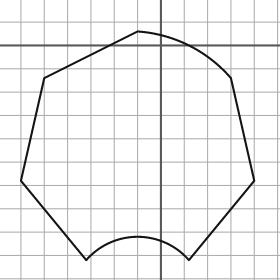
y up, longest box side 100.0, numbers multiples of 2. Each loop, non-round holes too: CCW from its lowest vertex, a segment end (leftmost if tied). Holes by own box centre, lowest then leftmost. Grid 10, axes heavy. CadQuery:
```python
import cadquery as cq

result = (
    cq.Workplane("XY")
    .moveTo(-32.0, -92.0)
    .threePointArc((-10.0, -82.0), (12.0, -92.0))
    .lineTo(40.0, -58.0)
    .lineTo(30.0, -14.0)
    .threePointArc((12.0, 0.0), (-10.0, 6.0))
    .lineTo(-50.0, -14.0)
    .lineTo(-60.0, -58.0)
    .close()
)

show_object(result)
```